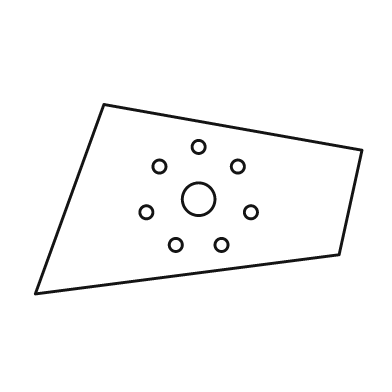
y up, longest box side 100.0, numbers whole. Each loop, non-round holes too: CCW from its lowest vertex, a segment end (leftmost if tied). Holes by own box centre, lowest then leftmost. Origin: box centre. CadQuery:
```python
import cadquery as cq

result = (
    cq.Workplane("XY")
    .moveTo(-50.0, -29.0)
    .lineTo(43.0, -17.0)
    .lineTo(50.0, 15.0)
    .lineTo(-29.0, 29.0)
    .close()
    .moveTo(-7.0, -14.0)
    .circle(2.0)
    .moveTo(7.0, -14.0)
    .circle(2.0)
    .moveTo(-16.0, -4.0)
    .circle(2.0)
    .moveTo(16.0, -4.0)
    .circle(2.0)
    .moveTo(0.0, 0.0)
    .circle(5.0)
    .moveTo(-12.0, 10.0)
    .circle(2.0)
    .moveTo(12.0, 10.0)
    .circle(2.0)
    .moveTo(0.0, 16.0)
    .circle(2.0)
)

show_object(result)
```